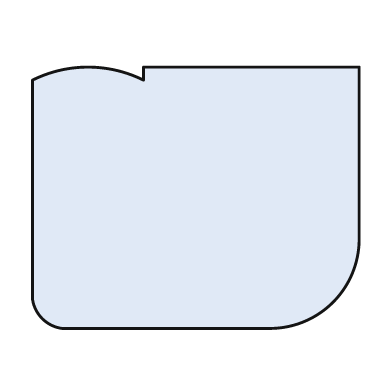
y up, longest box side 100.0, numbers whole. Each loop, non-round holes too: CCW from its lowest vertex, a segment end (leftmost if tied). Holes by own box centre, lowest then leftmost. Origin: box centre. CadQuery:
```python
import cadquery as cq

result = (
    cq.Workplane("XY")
    .moveTo(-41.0, -40.0)
    .lineTo(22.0, -40.0)
    .threePointArc((42.0, -32.0), (50.0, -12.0))
    .lineTo(50.0, 40.0)
    .lineTo(-16.0, 40.0)
    .lineTo(-16.0, 36.0)
    .threePointArc((-33.0, 40.0), (-50.0, 36.0))
    .lineTo(-50.0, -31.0)
    .threePointArc((-47.0, -37.0), (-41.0, -40.0))
    .close()
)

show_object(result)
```